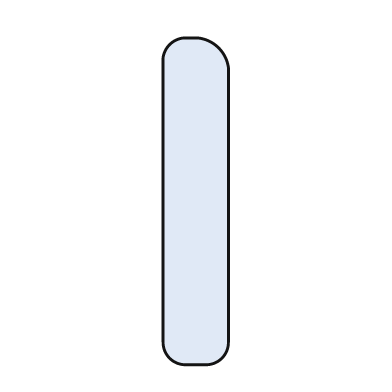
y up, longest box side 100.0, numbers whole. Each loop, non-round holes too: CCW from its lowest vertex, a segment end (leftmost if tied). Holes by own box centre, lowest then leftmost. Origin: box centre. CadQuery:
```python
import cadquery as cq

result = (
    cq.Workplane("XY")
    .moveTo(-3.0, -50.0)
    .lineTo(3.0, -50.0)
    .threePointArc((8.0, -48.0), (10.0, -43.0))
    .lineTo(10.0, 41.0)
    .threePointArc((7.0, 47.0), (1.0, 50.0))
    .lineTo(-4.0, 50.0)
    .threePointArc((-8.0, 48.0), (-10.0, 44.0))
    .lineTo(-10.0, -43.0)
    .threePointArc((-8.0, -48.0), (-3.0, -50.0))
    .close()
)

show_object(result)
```